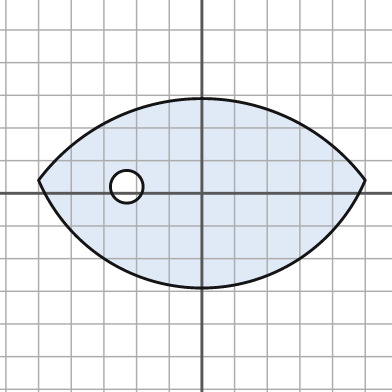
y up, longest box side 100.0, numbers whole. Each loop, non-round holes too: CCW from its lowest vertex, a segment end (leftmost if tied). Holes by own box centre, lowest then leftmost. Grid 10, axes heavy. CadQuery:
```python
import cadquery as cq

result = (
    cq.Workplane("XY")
    .moveTo(-50.0, 4.0)
    .threePointArc((0.0, -29.0), (50.0, 4.0))
    .threePointArc((0.0, 29.0), (-50.0, 4.0))
    .close()
    .moveTo(-23.0, 2.0)
    .circle(5.0)
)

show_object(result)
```